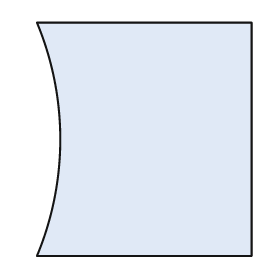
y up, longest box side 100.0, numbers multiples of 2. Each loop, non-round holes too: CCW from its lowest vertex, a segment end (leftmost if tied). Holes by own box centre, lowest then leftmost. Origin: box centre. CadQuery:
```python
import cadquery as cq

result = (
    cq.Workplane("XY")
    .moveTo(-46.0, -50.0)
    .lineTo(46.0, -50.0)
    .lineTo(46.0, 50.0)
    .lineTo(-46.0, 50.0)
    .threePointArc((-36.0, 0.0), (-46.0, -50.0))
    .close()
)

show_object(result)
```